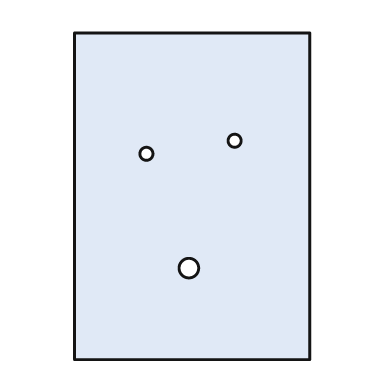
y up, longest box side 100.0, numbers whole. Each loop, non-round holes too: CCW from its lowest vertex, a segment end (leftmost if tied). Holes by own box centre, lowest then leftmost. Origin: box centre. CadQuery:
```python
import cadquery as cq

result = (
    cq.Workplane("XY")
    .moveTo(-36.0, -50.0)
    .lineTo(36.0, -50.0)
    .lineTo(36.0, 50.0)
    .lineTo(-36.0, 50.0)
    .close()
    .moveTo(-1.0, -22.0)
    .circle(3.0)
    .moveTo(-14.0, 13.0)
    .circle(2.0)
    .moveTo(13.0, 17.0)
    .circle(2.0)
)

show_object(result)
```